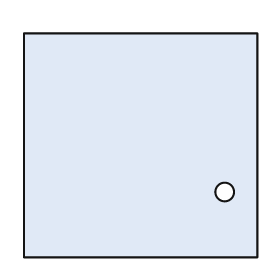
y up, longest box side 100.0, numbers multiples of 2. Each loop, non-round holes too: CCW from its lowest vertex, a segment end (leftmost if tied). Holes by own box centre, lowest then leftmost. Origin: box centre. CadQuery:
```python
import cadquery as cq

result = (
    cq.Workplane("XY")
    .moveTo(-50.0, -48.0)
    .lineTo(50.0, -48.0)
    .lineTo(50.0, 48.0)
    .lineTo(-50.0, 48.0)
    .close()
    .moveTo(36.0, -20.0)
    .circle(4.0)
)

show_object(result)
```